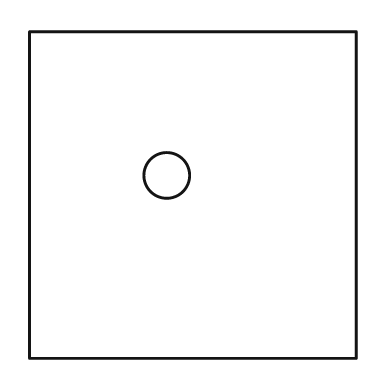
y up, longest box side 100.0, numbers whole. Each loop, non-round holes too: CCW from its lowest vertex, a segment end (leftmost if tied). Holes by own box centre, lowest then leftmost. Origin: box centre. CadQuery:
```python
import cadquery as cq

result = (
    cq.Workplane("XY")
    .moveTo(-50.0, -50.0)
    .lineTo(50.0, -50.0)
    .lineTo(50.0, 50.0)
    .lineTo(-50.0, 50.0)
    .close()
    .moveTo(-8.0, 6.0)
    .circle(7.0)
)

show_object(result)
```